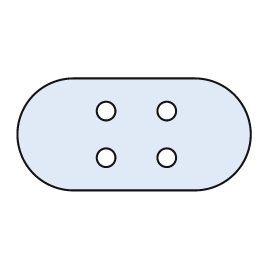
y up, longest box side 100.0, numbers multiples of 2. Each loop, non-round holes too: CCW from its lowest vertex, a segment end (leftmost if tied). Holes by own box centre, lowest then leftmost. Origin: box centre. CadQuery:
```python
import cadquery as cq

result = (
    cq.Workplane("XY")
    .moveTo(-26.0, -24.0)
    .lineTo(26.0, -24.0)
    .threePointArc((50.0, 0.0), (26.0, 24.0))
    .lineTo(-26.0, 24.0)
    .threePointArc((-50.0, 0.0), (-26.0, -24.0))
    .close()
    .moveTo(-12.0, -10.0)
    .circle(4.0)
    .moveTo(14.0, -10.0)
    .circle(4.0)
    .moveTo(-12.0, 10.0)
    .circle(4.0)
    .moveTo(14.0, 10.0)
    .circle(4.0)
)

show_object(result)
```